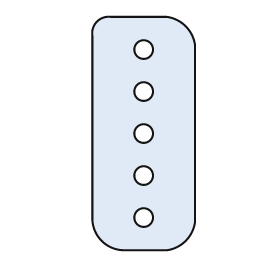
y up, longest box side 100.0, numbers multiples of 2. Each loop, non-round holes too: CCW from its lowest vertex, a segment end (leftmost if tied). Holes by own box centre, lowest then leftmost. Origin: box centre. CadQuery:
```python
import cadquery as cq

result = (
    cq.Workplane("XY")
    .moveTo(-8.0, -50.0)
    .lineTo(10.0, -50.0)
    .threePointArc((18.0, -46.0), (22.0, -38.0))
    .lineTo(22.0, 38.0)
    .threePointArc((18.0, 46.0), (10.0, 50.0))
    .lineTo(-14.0, 50.0)
    .threePointArc((-20.0, 48.0), (-22.0, 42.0))
    .lineTo(-22.0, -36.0)
    .threePointArc((-18.0, -46.0), (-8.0, -50.0))
    .close()
    .moveTo(0.0, -36.0)
    .circle(4.0)
    .moveTo(0.0, -18.0)
    .circle(4.0)
    .moveTo(0.0, 0.0)
    .circle(4.0)
    .moveTo(0.0, 18.0)
    .circle(4.0)
    .moveTo(0.0, 36.0)
    .circle(4.0)
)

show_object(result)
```